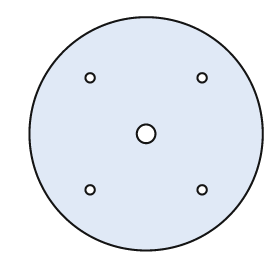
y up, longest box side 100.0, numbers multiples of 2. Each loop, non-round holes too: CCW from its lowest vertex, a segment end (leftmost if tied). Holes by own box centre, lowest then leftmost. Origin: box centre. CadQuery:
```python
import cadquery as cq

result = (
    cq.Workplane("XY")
    .moveTo(0.0, 0.0)
    .circle(50.0)
    .moveTo(-24.0, -24.0)
    .circle(2.0)
    .moveTo(24.0, -24.0)
    .circle(2.0)
    .moveTo(0.0, 0.0)
    .circle(4.0)
    .moveTo(-24.0, 24.0)
    .circle(2.0)
    .moveTo(24.0, 24.0)
    .circle(2.0)
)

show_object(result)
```